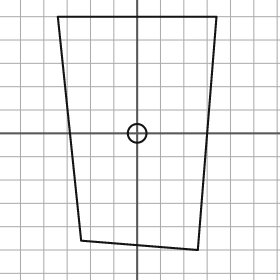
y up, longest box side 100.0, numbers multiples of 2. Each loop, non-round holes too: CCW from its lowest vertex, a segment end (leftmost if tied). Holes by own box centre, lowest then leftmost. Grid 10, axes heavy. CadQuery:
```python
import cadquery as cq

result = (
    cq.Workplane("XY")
    .moveTo(26.0, -50.0)
    .lineTo(34.0, 50.0)
    .lineTo(-34.0, 50.0)
    .lineTo(-24.0, -46.0)
    .close()
    .moveTo(0.0, 0.0)
    .circle(4.0)
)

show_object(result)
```